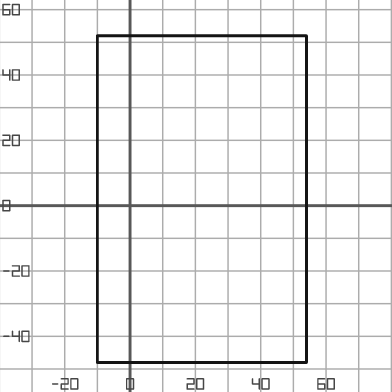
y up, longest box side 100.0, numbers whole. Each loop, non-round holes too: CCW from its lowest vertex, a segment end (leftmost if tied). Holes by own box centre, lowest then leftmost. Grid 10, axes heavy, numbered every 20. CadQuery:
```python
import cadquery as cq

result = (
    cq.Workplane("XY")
    .moveTo(-10.0, -48.0)
    .lineTo(54.0, -48.0)
    .lineTo(54.0, 52.0)
    .lineTo(-10.0, 52.0)
    .close()
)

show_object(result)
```